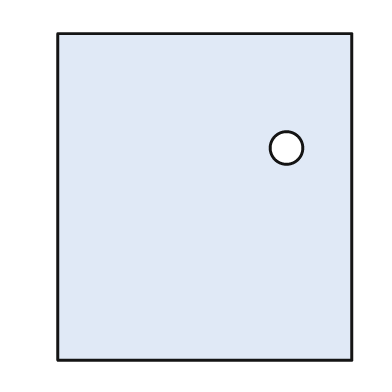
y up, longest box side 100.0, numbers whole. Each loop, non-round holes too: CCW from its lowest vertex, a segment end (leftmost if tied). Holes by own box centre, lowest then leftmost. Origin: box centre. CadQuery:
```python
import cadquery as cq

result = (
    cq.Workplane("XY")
    .moveTo(-45.0, -50.0)
    .lineTo(45.0, -50.0)
    .lineTo(45.0, 50.0)
    .lineTo(-45.0, 50.0)
    .close()
    .moveTo(25.0, 15.0)
    .circle(5.0)
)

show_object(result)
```